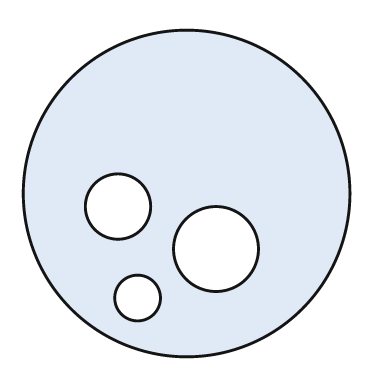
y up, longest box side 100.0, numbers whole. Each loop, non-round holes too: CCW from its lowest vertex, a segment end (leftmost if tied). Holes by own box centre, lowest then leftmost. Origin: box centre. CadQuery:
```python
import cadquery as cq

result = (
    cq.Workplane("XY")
    .moveTo(0.0, 0.0)
    .circle(50.0)
    .moveTo(-15.0, -32.0)
    .circle(7.0)
    .moveTo(9.0, -17.0)
    .circle(13.0)
    .moveTo(-21.0, -4.0)
    .circle(10.0)
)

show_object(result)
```